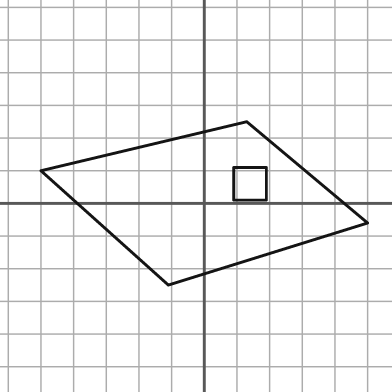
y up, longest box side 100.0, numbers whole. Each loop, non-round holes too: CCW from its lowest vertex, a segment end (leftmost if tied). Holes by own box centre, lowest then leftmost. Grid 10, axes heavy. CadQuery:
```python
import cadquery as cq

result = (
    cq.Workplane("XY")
    .moveTo(-11.0, -25.0)
    .lineTo(50.0, -6.0)
    .lineTo(13.0, 25.0)
    .lineTo(-50.0, 10.0)
    .close()
    .moveTo(9.0, 1.0)
    .lineTo(19.0, 1.0)
    .lineTo(19.0, 11.0)
    .lineTo(9.0, 11.0)
    .close()
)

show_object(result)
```